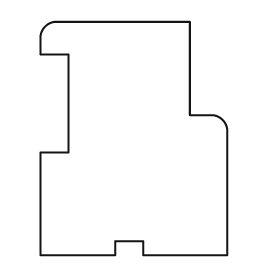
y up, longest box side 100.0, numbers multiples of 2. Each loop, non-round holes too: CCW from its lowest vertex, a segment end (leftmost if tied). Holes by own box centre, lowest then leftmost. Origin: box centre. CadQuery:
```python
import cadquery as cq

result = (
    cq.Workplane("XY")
    .moveTo(-40.0, -50.0)
    .lineTo(-8.0, -50.0)
    .lineTo(-8.0, -44.0)
    .lineTo(4.0, -44.0)
    .lineTo(4.0, -50.0)
    .lineTo(40.0, -50.0)
    .lineTo(40.0, 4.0)
    .threePointArc((38.0, 8.0), (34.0, 10.0))
    .lineTo(24.0, 10.0)
    .lineTo(24.0, 50.0)
    .lineTo(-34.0, 50.0)
    .threePointArc((-38.0, 48.0), (-40.0, 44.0))
    .lineTo(-40.0, 36.0)
    .lineTo(-28.0, 36.0)
    .lineTo(-28.0, -6.0)
    .lineTo(-40.0, -6.0)
    .close()
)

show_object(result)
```